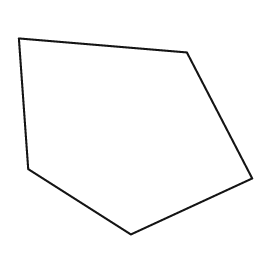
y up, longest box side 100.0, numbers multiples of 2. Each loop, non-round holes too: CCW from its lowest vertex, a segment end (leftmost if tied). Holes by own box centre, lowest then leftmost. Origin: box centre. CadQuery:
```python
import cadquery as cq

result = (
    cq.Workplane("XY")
    .moveTo(-2.0, -42.0)
    .lineTo(50.0, -18.0)
    .lineTo(22.0, 36.0)
    .lineTo(-50.0, 42.0)
    .lineTo(-46.0, -14.0)
    .close()
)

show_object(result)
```